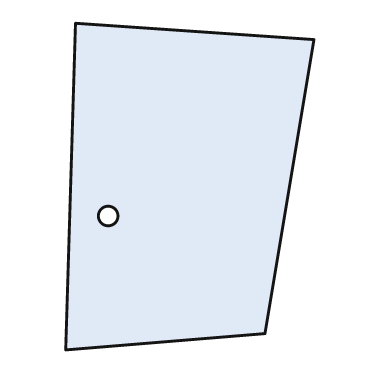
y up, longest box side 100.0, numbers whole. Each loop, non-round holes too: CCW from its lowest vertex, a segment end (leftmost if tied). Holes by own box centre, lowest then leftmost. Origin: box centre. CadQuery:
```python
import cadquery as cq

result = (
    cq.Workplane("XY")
    .moveTo(-38.0, -50.0)
    .lineTo(23.0, -45.0)
    .lineTo(38.0, 45.0)
    .lineTo(-35.0, 50.0)
    .close()
    .moveTo(-25.0, -9.0)
    .circle(3.0)
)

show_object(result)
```